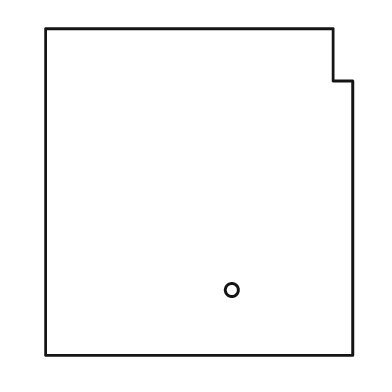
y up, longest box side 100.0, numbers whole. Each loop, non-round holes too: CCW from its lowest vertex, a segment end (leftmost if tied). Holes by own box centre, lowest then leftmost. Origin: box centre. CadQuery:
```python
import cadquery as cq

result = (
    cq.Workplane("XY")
    .moveTo(-47.0, -50.0)
    .lineTo(47.0, -50.0)
    .lineTo(47.0, 34.0)
    .lineTo(41.0, 34.0)
    .lineTo(41.0, 50.0)
    .lineTo(-47.0, 50.0)
    .close()
    .moveTo(10.0, -30.0)
    .circle(2.0)
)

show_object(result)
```